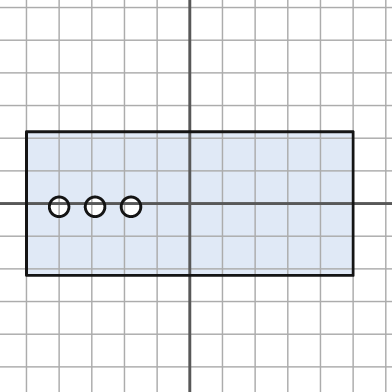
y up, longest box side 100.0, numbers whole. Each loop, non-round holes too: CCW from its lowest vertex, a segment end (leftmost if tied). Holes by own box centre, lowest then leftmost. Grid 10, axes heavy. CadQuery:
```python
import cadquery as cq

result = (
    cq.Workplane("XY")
    .moveTo(-50.0, -22.0)
    .lineTo(50.0, -22.0)
    .lineTo(50.0, 22.0)
    .lineTo(-50.0, 22.0)
    .close()
    .moveTo(-40.0, -1.0)
    .circle(3.0)
    .moveTo(-29.0, -1.0)
    .circle(3.0)
    .moveTo(-18.0, -1.0)
    .circle(3.0)
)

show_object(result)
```